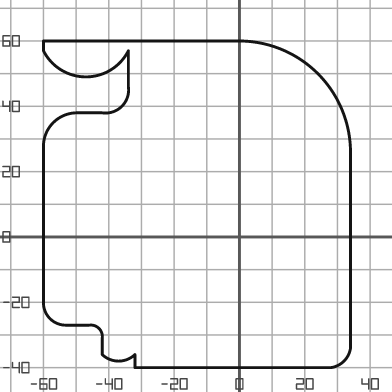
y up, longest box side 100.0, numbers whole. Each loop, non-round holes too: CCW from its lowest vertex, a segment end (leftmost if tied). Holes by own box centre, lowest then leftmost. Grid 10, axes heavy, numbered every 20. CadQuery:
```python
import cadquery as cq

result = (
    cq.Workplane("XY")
    .moveTo(-32.0, -40.0)
    .lineTo(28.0, -40.0)
    .threePointArc((32.0, -38.0), (34.0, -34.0))
    .lineTo(34.0, 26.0)
    .threePointArc((24.0, 50.0), (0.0, 60.0))
    .lineTo(-60.0, 60.0)
    .lineTo(-60.0, 57.0)
    .threePointArc((-47.0, 49.0), (-34.0, 57.0))
    .lineTo(-34.0, 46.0)
    .threePointArc((-36.0, 40.0), (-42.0, 38.0))
    .lineTo(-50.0, 38.0)
    .threePointArc((-57.0, 35.0), (-60.0, 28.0))
    .lineTo(-60.0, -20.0)
    .threePointArc((-58.0, -25.0), (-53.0, -27.0))
    .lineTo(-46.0, -27.0)
    .threePointArc((-43.0, -28.0), (-42.0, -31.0))
    .lineTo(-42.0, -36.0)
    .threePointArc((-37.0, -38.0), (-32.0, -36.0))
    .close()
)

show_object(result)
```